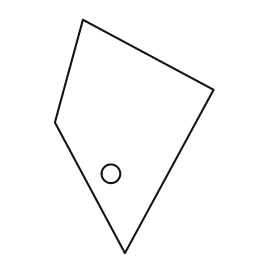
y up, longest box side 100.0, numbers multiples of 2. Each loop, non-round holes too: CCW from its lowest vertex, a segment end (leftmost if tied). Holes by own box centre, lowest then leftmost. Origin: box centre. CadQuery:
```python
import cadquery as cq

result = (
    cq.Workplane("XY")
    .moveTo(-4.0, -50.0)
    .lineTo(34.0, 20.0)
    .lineTo(-22.0, 50.0)
    .lineTo(-34.0, 6.0)
    .close()
    .moveTo(-10.0, -16.0)
    .circle(4.0)
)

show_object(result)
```